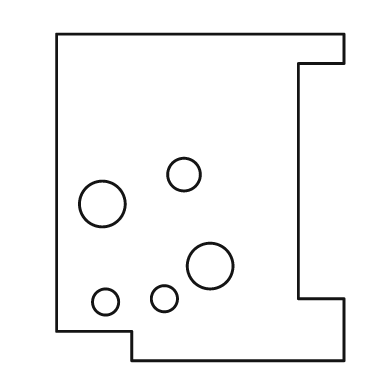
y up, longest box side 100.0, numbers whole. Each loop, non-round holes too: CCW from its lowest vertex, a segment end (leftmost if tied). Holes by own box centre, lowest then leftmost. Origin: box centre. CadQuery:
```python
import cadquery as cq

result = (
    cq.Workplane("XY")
    .moveTo(-21.0, -50.0)
    .lineTo(44.0, -50.0)
    .lineTo(44.0, -31.0)
    .lineTo(30.0, -31.0)
    .lineTo(30.0, 41.0)
    .lineTo(44.0, 41.0)
    .lineTo(44.0, 50.0)
    .lineTo(-44.0, 50.0)
    .lineTo(-44.0, -41.0)
    .lineTo(-21.0, -41.0)
    .close()
    .moveTo(-29.0, -32.0)
    .circle(4.0)
    .moveTo(-11.0, -31.0)
    .circle(4.0)
    .moveTo(3.0, -21.0)
    .circle(7.0)
    .moveTo(-30.0, -2.0)
    .circle(7.0)
    .moveTo(-5.0, 7.0)
    .circle(5.0)
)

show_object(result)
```